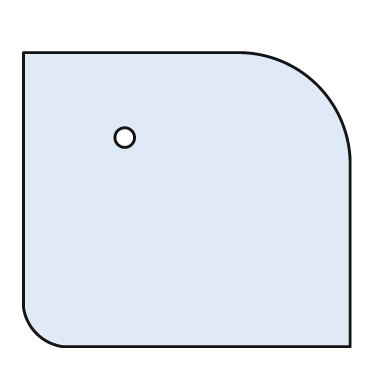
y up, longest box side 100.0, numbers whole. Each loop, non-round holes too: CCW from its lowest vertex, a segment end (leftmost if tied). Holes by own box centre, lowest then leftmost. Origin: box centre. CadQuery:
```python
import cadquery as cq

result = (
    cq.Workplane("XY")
    .moveTo(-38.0, -45.0)
    .lineTo(50.0, -45.0)
    .lineTo(50.0, 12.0)
    .threePointArc((40.0, 35.0), (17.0, 45.0))
    .lineTo(-50.0, 45.0)
    .lineTo(-50.0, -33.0)
    .threePointArc((-46.0, -41.0), (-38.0, -45.0))
    .close()
    .moveTo(-19.0, 19.0)
    .circle(3.0)
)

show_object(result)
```